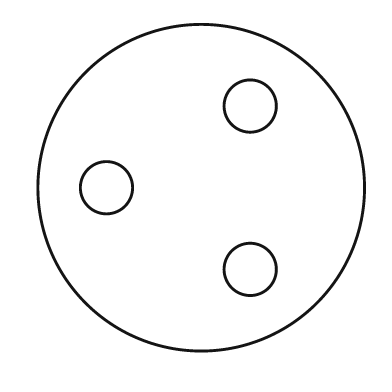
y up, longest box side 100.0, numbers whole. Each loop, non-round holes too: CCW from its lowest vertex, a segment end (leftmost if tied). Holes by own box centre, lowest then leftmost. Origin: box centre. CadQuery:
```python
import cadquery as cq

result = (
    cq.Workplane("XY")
    .moveTo(0.0, 0.0)
    .circle(50.0)
    .moveTo(15.0, -25.0)
    .circle(8.0)
    .moveTo(-29.0, 0.0)
    .circle(8.0)
    .moveTo(15.0, 25.0)
    .circle(8.0)
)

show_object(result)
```